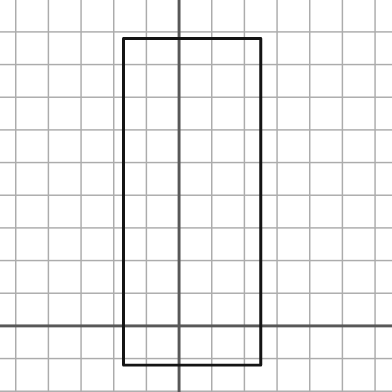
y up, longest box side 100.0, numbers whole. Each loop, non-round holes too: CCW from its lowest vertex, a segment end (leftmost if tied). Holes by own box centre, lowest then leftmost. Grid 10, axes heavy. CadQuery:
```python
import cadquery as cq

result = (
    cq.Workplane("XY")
    .moveTo(-17.0, -12.0)
    .lineTo(25.0, -12.0)
    .lineTo(25.0, 88.0)
    .lineTo(-17.0, 88.0)
    .close()
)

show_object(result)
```